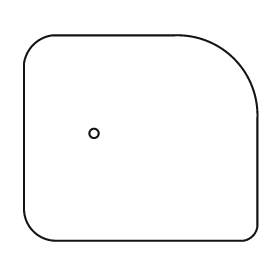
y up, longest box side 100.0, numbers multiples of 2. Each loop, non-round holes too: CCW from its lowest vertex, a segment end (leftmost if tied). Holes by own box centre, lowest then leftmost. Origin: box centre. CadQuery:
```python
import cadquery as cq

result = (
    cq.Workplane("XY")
    .moveTo(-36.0, -44.0)
    .lineTo(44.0, -44.0)
    .threePointArc((48.0, -42.0), (50.0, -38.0))
    .lineTo(50.0, 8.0)
    .threePointArc((40.0, 34.0), (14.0, 44.0))
    .lineTo(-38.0, 44.0)
    .threePointArc((-46.0, 40.0), (-50.0, 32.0))
    .lineTo(-50.0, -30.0)
    .threePointArc((-46.0, -40.0), (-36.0, -44.0))
    .close()
    .moveTo(-20.0, 2.0)
    .circle(2.0)
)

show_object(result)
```